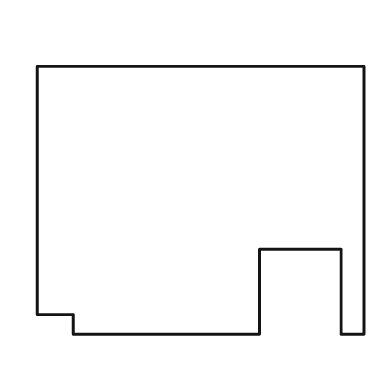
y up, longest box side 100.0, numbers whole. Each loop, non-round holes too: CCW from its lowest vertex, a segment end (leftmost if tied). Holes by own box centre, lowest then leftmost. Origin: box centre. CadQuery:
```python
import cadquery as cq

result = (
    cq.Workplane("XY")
    .moveTo(-39.0, -41.0)
    .lineTo(18.0, -41.0)
    .lineTo(18.0, -15.0)
    .lineTo(43.0, -15.0)
    .lineTo(43.0, -41.0)
    .lineTo(50.0, -41.0)
    .lineTo(50.0, 41.0)
    .lineTo(-50.0, 41.0)
    .lineTo(-50.0, -35.0)
    .lineTo(-39.0, -35.0)
    .close()
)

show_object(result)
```